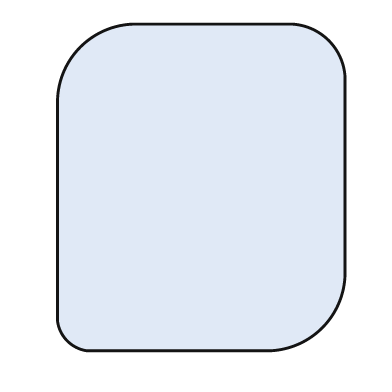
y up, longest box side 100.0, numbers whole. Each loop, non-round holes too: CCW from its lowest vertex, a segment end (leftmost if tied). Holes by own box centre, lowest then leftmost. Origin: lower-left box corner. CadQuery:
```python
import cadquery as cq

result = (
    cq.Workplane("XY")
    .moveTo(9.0, 0.0)
    .lineTo(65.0, 0.0)
    .threePointArc((81.0, 7.0), (88.0, 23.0))
    .lineTo(88.0, 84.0)
    .threePointArc((83.0, 95.0), (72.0, 100.0))
    .lineTo(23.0, 100.0)
    .threePointArc((7.0, 93.0), (0.0, 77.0))
    .lineTo(0.0, 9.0)
    .threePointArc((3.0, 3.0), (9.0, 0.0))
    .close()
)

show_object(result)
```